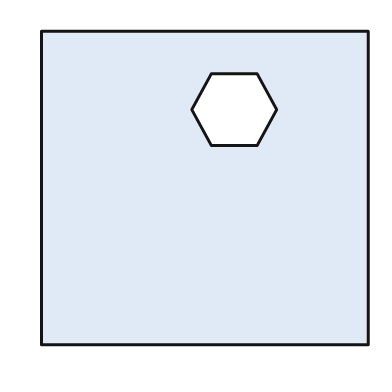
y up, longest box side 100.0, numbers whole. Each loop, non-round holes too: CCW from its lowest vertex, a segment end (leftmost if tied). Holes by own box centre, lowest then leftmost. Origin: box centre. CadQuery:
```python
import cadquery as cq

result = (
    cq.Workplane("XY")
    .moveTo(-50.0, -48.0)
    .lineTo(50.0, -48.0)
    .lineTo(50.0, 48.0)
    .lineTo(-50.0, 48.0)
    .close()
    .moveTo(2.0, 13.0)
    .lineTo(16.0, 13.0)
    .lineTo(22.0, 24.0)
    .lineTo(16.0, 35.0)
    .lineTo(2.0, 35.0)
    .lineTo(-4.0, 24.0)
    .close()
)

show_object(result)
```